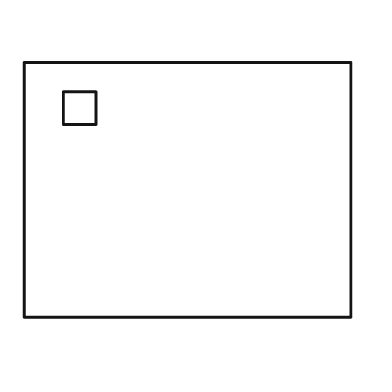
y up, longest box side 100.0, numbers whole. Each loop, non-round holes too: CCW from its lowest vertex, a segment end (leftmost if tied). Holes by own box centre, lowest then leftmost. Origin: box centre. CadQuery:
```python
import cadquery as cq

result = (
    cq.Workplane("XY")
    .moveTo(-50.0, -39.0)
    .lineTo(50.0, -39.0)
    .lineTo(50.0, 39.0)
    .lineTo(-50.0, 39.0)
    .close()
    .moveTo(-38.0, 20.0)
    .lineTo(-28.0, 20.0)
    .lineTo(-28.0, 30.0)
    .lineTo(-38.0, 30.0)
    .close()
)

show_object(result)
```